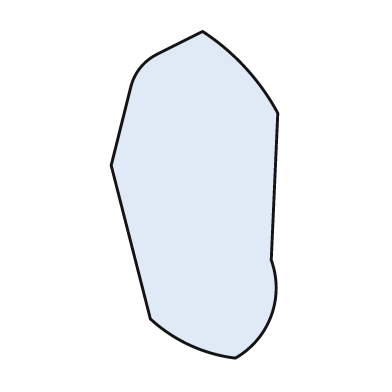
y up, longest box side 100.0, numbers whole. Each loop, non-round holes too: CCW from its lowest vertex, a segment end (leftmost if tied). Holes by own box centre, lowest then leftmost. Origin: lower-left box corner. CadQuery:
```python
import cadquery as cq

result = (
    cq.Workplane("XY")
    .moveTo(38.0, 0.0)
    .threePointArc((49.0, 13.0), (49.0, 30.0))
    .lineTo(51.0, 75.0)
    .threePointArc((41.0, 89.0), (28.0, 100.0))
    .lineTo(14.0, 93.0)
    .threePointArc((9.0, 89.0), (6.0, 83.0))
    .lineTo(0.0, 59.0)
    .lineTo(12.0, 12.0)
    .threePointArc((24.0, 4.0), (38.0, 0.0))
    .close()
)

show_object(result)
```